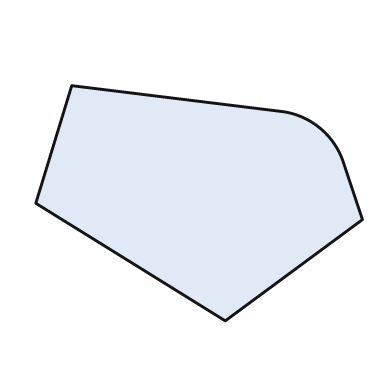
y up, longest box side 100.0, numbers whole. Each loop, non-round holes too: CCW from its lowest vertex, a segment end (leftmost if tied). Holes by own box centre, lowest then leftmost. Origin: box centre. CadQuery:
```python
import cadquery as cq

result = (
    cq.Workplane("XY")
    .moveTo(8.0, -36.0)
    .lineTo(50.0, -5.0)
    .lineTo(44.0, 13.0)
    .threePointArc((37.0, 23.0), (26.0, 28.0))
    .lineTo(-39.0, 36.0)
    .lineTo(-50.0, 0.0)
    .close()
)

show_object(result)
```